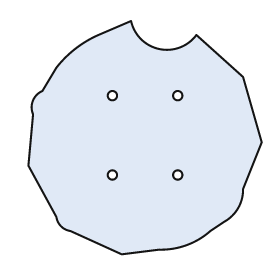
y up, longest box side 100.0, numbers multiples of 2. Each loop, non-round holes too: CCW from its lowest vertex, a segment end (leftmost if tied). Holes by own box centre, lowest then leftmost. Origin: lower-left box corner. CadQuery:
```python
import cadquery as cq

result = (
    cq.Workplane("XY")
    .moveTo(40.0, 0.0)
    .lineTo(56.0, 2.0)
    .threePointArc((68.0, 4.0), (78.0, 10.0))
    .lineTo(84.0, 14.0)
    .threePointArc((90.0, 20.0), (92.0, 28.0))
    .lineTo(100.0, 48.0)
    .lineTo(92.0, 76.0)
    .lineTo(72.0, 94.0)
    .threePointArc((56.0, 88.0), (44.0, 100.0))
    .lineTo(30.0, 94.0)
    .threePointArc((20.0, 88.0), (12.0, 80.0))
    .lineTo(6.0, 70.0)
    .threePointArc((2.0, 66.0), (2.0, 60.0))
    .lineTo(0.0, 38.0)
    .lineTo(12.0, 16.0)
    .threePointArc((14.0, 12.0), (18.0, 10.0))
    .close()
    .moveTo(36.0, 34.0)
    .circle(2.0)
    .moveTo(64.0, 34.0)
    .circle(2.0)
    .moveTo(36.0, 68.0)
    .circle(2.0)
    .moveTo(64.0, 68.0)
    .circle(2.0)
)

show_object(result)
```